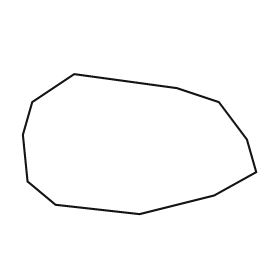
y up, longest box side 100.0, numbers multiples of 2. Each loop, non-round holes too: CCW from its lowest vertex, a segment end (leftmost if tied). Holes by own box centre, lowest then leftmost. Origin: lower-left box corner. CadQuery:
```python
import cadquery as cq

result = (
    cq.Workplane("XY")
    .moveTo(50.0, 0.0)
    .lineTo(82.0, 8.0)
    .lineTo(100.0, 18.0)
    .lineTo(96.0, 32.0)
    .lineTo(84.0, 48.0)
    .lineTo(66.0, 54.0)
    .lineTo(22.0, 60.0)
    .lineTo(4.0, 48.0)
    .lineTo(0.0, 34.0)
    .lineTo(2.0, 14.0)
    .lineTo(14.0, 4.0)
    .close()
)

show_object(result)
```